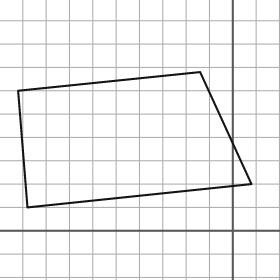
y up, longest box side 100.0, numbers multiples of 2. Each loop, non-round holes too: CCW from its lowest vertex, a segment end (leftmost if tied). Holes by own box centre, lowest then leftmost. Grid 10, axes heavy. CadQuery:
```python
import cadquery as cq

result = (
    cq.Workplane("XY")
    .moveTo(-88.0, 10.0)
    .lineTo(8.0, 20.0)
    .lineTo(-14.0, 68.0)
    .lineTo(-92.0, 60.0)
    .close()
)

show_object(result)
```